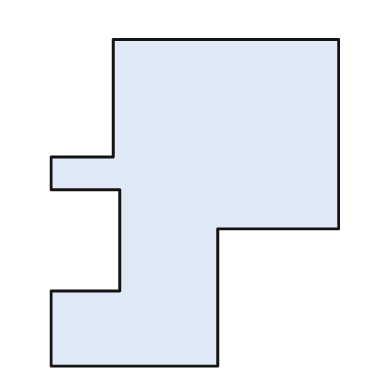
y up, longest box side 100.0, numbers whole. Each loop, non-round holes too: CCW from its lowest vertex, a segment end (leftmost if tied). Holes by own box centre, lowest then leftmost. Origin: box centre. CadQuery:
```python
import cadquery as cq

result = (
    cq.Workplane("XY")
    .moveTo(-44.0, -50.0)
    .lineTo(7.0, -50.0)
    .lineTo(7.0, -8.0)
    .lineTo(44.0, -8.0)
    .lineTo(44.0, 50.0)
    .lineTo(-25.0, 50.0)
    .lineTo(-25.0, 14.0)
    .lineTo(-44.0, 14.0)
    .lineTo(-44.0, 4.0)
    .lineTo(-23.0, 4.0)
    .lineTo(-23.0, -27.0)
    .lineTo(-44.0, -27.0)
    .close()
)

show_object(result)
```